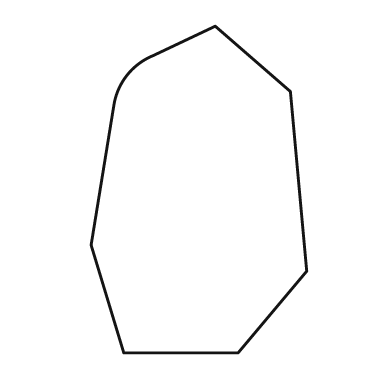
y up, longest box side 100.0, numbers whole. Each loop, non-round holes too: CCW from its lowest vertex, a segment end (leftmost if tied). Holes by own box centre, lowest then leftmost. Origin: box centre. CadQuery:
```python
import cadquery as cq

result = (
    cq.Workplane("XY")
    .moveTo(-23.0, -50.0)
    .lineTo(12.0, -50.0)
    .lineTo(33.0, -25.0)
    .lineTo(28.0, 30.0)
    .lineTo(5.0, 50.0)
    .lineTo(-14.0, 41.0)
    .threePointArc((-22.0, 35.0), (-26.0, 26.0))
    .lineTo(-33.0, -17.0)
    .close()
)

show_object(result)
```